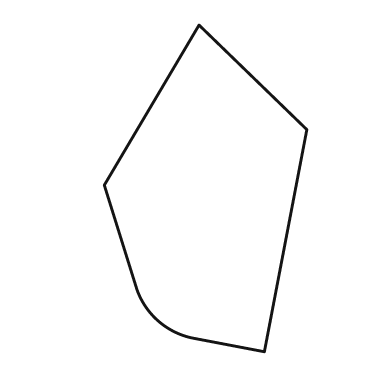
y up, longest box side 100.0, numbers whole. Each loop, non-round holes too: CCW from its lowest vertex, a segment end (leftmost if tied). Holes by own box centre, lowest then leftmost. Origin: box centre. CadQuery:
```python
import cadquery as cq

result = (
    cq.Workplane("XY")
    .moveTo(18.0, -50.0)
    .lineTo(31.0, 18.0)
    .lineTo(-2.0, 50.0)
    .lineTo(-31.0, 1.0)
    .lineTo(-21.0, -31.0)
    .threePointArc((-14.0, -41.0), (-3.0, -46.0))
    .close()
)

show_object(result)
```